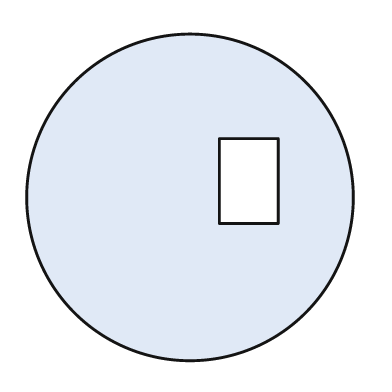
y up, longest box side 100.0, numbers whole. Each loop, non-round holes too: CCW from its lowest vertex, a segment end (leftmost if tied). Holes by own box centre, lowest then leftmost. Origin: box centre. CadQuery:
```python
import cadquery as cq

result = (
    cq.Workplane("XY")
    .moveTo(0.0, 0.0)
    .circle(50.0)
    .moveTo(9.0, -8.0)
    .lineTo(27.0, -8.0)
    .lineTo(27.0, 18.0)
    .lineTo(9.0, 18.0)
    .close()
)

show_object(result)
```